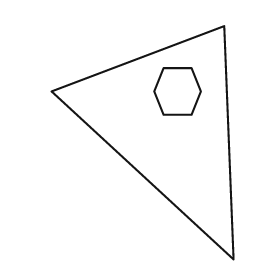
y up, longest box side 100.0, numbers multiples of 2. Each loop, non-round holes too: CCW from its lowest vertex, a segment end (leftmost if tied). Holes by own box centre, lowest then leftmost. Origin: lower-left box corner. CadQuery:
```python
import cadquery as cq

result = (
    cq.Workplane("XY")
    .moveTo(78.0, 0.0)
    .lineTo(74.0, 100.0)
    .lineTo(0.0, 72.0)
    .close()
    .moveTo(48.0, 62.0)
    .lineTo(60.0, 62.0)
    .lineTo(64.0, 72.0)
    .lineTo(60.0, 82.0)
    .lineTo(48.0, 82.0)
    .lineTo(44.0, 72.0)
    .close()
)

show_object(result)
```